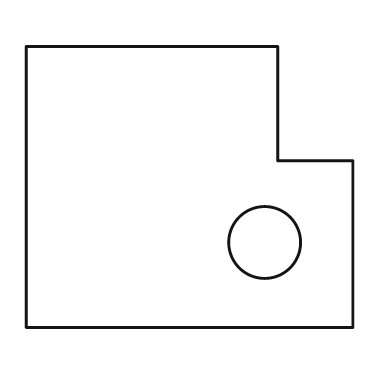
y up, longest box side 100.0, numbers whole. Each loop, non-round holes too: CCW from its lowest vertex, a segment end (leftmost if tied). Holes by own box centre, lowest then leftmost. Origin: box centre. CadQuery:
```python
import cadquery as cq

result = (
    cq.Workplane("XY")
    .moveTo(-50.0, -43.0)
    .lineTo(50.0, -43.0)
    .lineTo(50.0, 8.0)
    .lineTo(27.0, 8.0)
    .lineTo(27.0, 43.0)
    .lineTo(-50.0, 43.0)
    .close()
    .moveTo(23.0, -17.0)
    .circle(11.0)
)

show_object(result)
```